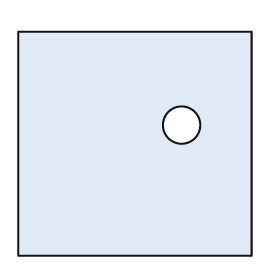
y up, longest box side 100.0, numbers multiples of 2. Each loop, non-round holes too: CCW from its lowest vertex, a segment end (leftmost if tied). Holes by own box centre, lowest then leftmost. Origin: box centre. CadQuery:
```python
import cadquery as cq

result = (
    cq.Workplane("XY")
    .moveTo(-50.0, -48.0)
    .lineTo(50.0, -48.0)
    .lineTo(50.0, 48.0)
    .lineTo(-50.0, 48.0)
    .close()
    .moveTo(20.0, 8.0)
    .circle(8.0)
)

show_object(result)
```